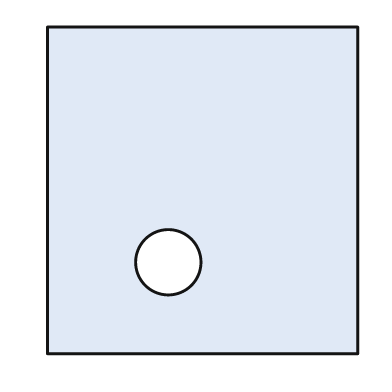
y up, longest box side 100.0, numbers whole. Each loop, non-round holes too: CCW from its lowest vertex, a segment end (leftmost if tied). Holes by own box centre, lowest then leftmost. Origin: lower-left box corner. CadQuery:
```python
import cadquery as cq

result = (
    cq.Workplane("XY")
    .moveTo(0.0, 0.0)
    .lineTo(95.0, 0.0)
    .lineTo(95.0, 100.0)
    .lineTo(0.0, 100.0)
    .close()
    .moveTo(37.0, 28.0)
    .circle(10.0)
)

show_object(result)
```